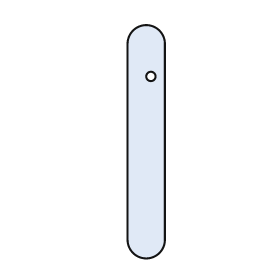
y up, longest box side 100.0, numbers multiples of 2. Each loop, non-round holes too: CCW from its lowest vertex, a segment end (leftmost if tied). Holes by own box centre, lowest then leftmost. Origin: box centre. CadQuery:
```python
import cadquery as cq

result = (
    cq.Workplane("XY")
    .moveTo(-8.0, -42.0)
    .threePointArc((0.0, -50.0), (8.0, -42.0))
    .lineTo(8.0, 42.0)
    .threePointArc((0.0, 50.0), (-8.0, 42.0))
    .close()
    .moveTo(2.0, 28.0)
    .circle(2.0)
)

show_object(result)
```